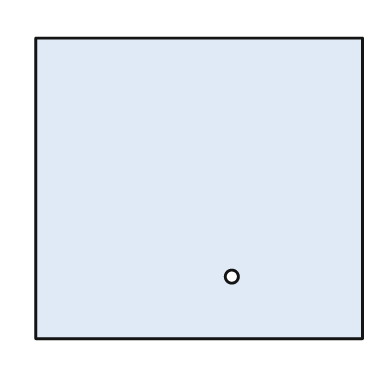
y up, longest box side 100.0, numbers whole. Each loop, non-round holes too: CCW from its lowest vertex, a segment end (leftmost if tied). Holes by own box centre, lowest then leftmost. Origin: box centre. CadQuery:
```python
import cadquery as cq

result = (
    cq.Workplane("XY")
    .moveTo(-50.0, -46.0)
    .lineTo(50.0, -46.0)
    .lineTo(50.0, 46.0)
    .lineTo(-50.0, 46.0)
    .close()
    .moveTo(10.0, -27.0)
    .circle(2.0)
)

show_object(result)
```